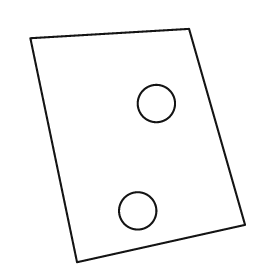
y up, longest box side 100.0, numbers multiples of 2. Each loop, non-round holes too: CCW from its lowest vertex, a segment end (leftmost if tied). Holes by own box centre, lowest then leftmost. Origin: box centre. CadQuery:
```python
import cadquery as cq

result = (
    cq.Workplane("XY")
    .moveTo(-26.0, -50.0)
    .lineTo(46.0, -34.0)
    .lineTo(22.0, 50.0)
    .lineTo(-46.0, 46.0)
    .close()
    .moveTo(0.0, -28.0)
    .circle(8.0)
    .moveTo(8.0, 18.0)
    .circle(8.0)
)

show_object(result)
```